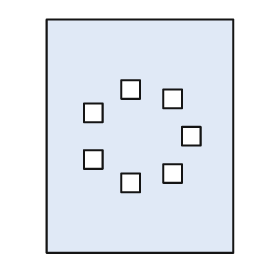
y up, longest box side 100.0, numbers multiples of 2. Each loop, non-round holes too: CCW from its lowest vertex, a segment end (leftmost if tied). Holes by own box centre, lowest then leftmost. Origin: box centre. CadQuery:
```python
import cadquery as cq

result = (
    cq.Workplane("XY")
    .moveTo(-40.0, -50.0)
    .lineTo(40.0, -50.0)
    .lineTo(40.0, 50.0)
    .lineTo(-40.0, 50.0)
    .close()
    .moveTo(-8.0, -24.0)
    .lineTo(0.0, -24.0)
    .lineTo(0.0, -16.0)
    .lineTo(-8.0, -16.0)
    .close()
    .moveTo(10.0, -20.0)
    .lineTo(18.0, -20.0)
    .lineTo(18.0, -12.0)
    .lineTo(10.0, -12.0)
    .close()
    .moveTo(-24.0, -14.0)
    .lineTo(-16.0, -14.0)
    .lineTo(-16.0, -6.0)
    .lineTo(-24.0, -6.0)
    .close()
    .moveTo(18.0, -4.0)
    .lineTo(26.0, -4.0)
    .lineTo(26.0, 4.0)
    .lineTo(18.0, 4.0)
    .close()
    .moveTo(-24.0, 6.0)
    .lineTo(-16.0, 6.0)
    .lineTo(-16.0, 14.0)
    .lineTo(-24.0, 14.0)
    .close()
    .moveTo(10.0, 12.0)
    .lineTo(18.0, 12.0)
    .lineTo(18.0, 20.0)
    .lineTo(10.0, 20.0)
    .close()
    .moveTo(-8.0, 16.0)
    .lineTo(0.0, 16.0)
    .lineTo(0.0, 24.0)
    .lineTo(-8.0, 24.0)
    .close()
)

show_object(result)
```